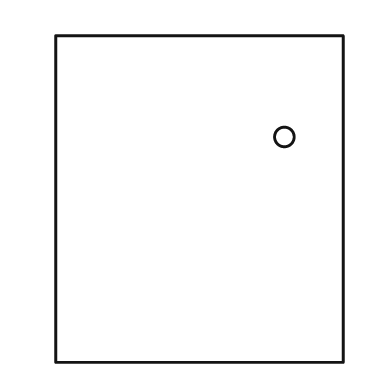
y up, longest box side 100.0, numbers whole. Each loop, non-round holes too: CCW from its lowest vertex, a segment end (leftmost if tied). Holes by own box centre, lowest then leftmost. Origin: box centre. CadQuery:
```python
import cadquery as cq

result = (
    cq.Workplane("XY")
    .moveTo(-44.0, -50.0)
    .lineTo(44.0, -50.0)
    .lineTo(44.0, 50.0)
    .lineTo(-44.0, 50.0)
    .close()
    .moveTo(26.0, 19.0)
    .circle(3.0)
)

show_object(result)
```